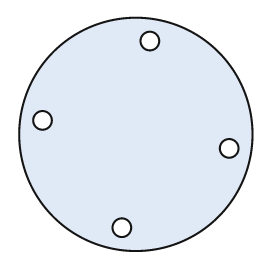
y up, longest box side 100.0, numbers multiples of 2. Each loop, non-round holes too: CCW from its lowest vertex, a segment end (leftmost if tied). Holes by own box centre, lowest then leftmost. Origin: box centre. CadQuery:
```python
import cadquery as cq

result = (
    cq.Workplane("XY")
    .moveTo(0.0, 0.0)
    .circle(50.0)
    .moveTo(-6.0, -40.0)
    .circle(4.0)
    .moveTo(40.0, -6.0)
    .circle(4.0)
    .moveTo(-40.0, 6.0)
    .circle(4.0)
    .moveTo(6.0, 40.0)
    .circle(4.0)
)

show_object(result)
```